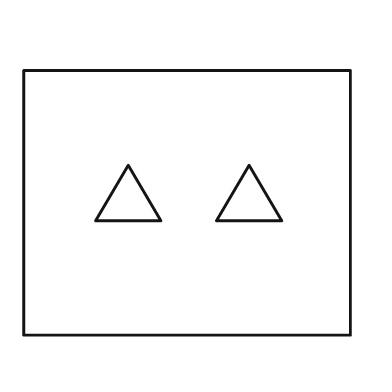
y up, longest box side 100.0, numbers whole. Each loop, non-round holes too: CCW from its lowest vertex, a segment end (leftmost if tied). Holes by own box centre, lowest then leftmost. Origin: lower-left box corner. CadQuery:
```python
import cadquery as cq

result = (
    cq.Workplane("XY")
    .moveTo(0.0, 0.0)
    .lineTo(100.0, 0.0)
    .lineTo(100.0, 81.0)
    .lineTo(0.0, 81.0)
    .close()
    .moveTo(22.0, 35.0)
    .lineTo(42.0, 35.0)
    .lineTo(32.0, 52.0)
    .close()
    .moveTo(59.0, 35.0)
    .lineTo(79.0, 35.0)
    .lineTo(69.0, 52.0)
    .close()
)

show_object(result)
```